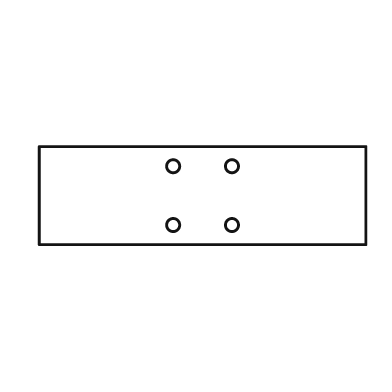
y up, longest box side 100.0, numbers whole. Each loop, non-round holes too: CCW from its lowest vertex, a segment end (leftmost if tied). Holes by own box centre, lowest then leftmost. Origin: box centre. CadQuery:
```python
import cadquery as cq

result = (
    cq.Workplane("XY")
    .moveTo(-50.0, -15.0)
    .lineTo(50.0, -15.0)
    .lineTo(50.0, 15.0)
    .lineTo(-50.0, 15.0)
    .close()
    .moveTo(-9.0, -9.0)
    .circle(2.0)
    .moveTo(9.0, -9.0)
    .circle(2.0)
    .moveTo(-9.0, 9.0)
    .circle(2.0)
    .moveTo(9.0, 9.0)
    .circle(2.0)
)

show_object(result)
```